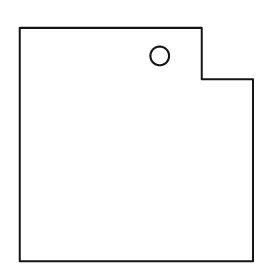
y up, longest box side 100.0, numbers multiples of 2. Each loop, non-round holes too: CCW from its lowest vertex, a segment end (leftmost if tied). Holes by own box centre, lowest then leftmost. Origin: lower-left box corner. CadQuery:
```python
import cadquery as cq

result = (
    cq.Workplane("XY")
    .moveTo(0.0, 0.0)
    .lineTo(100.0, 0.0)
    .lineTo(100.0, 78.0)
    .lineTo(78.0, 78.0)
    .lineTo(78.0, 100.0)
    .lineTo(0.0, 100.0)
    .close()
    .moveTo(60.0, 88.0)
    .circle(4.0)
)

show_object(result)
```